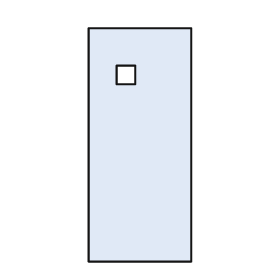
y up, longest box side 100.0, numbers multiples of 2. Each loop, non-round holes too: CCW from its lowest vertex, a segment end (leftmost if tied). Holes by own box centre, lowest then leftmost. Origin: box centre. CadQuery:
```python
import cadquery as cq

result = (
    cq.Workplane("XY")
    .moveTo(-22.0, -50.0)
    .lineTo(22.0, -50.0)
    .lineTo(22.0, 50.0)
    .lineTo(-22.0, 50.0)
    .close()
    .moveTo(-10.0, 26.0)
    .lineTo(-2.0, 26.0)
    .lineTo(-2.0, 34.0)
    .lineTo(-10.0, 34.0)
    .close()
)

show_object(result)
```